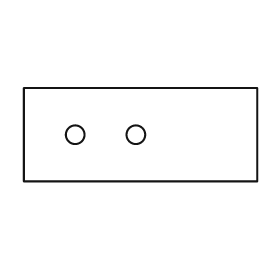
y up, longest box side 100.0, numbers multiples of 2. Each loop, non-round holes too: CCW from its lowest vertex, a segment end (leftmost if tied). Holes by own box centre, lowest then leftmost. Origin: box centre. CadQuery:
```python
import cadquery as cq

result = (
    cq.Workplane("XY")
    .moveTo(-50.0, -20.0)
    .lineTo(50.0, -20.0)
    .lineTo(50.0, 20.0)
    .lineTo(-50.0, 20.0)
    .close()
    .moveTo(-28.0, 0.0)
    .circle(4.0)
    .moveTo(-2.0, 0.0)
    .circle(4.0)
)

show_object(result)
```